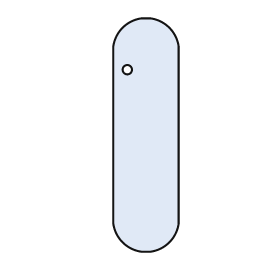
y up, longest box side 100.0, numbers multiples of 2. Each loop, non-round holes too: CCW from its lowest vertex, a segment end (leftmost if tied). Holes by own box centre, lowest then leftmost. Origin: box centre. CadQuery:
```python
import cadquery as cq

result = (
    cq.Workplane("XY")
    .moveTo(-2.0, -50.0)
    .lineTo(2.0, -50.0)
    .threePointArc((10.0, -46.0), (14.0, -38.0))
    .lineTo(14.0, 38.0)
    .threePointArc((10.0, 46.0), (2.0, 50.0))
    .lineTo(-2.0, 50.0)
    .threePointArc((-10.0, 46.0), (-14.0, 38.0))
    .lineTo(-14.0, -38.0)
    .threePointArc((-10.0, -46.0), (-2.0, -50.0))
    .close()
    .moveTo(-8.0, 28.0)
    .circle(2.0)
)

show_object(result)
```